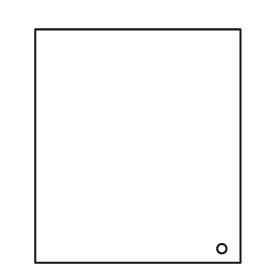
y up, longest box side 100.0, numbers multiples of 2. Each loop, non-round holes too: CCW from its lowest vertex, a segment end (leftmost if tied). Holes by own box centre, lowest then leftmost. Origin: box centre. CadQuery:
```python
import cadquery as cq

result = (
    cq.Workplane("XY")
    .moveTo(-44.0, -50.0)
    .lineTo(44.0, -50.0)
    .lineTo(44.0, 50.0)
    .lineTo(-44.0, 50.0)
    .close()
    .moveTo(36.0, -44.0)
    .circle(2.0)
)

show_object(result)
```